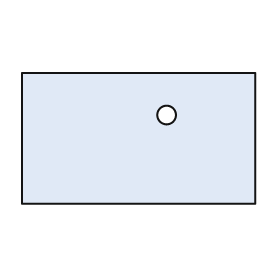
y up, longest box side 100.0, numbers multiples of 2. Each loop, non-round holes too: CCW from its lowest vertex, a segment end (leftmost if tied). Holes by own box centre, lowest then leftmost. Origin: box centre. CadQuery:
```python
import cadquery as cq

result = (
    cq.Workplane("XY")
    .moveTo(-50.0, -28.0)
    .lineTo(50.0, -28.0)
    .lineTo(50.0, 28.0)
    .lineTo(-50.0, 28.0)
    .close()
    .moveTo(12.0, 10.0)
    .circle(4.0)
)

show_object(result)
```